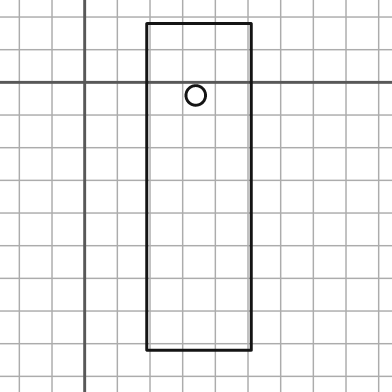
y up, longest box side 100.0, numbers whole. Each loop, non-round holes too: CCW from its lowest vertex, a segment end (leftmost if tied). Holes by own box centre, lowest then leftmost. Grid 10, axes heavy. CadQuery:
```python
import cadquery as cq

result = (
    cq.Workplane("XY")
    .moveTo(19.0, -82.0)
    .lineTo(51.0, -82.0)
    .lineTo(51.0, 18.0)
    .lineTo(19.0, 18.0)
    .close()
    .moveTo(34.0, -4.0)
    .circle(3.0)
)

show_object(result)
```